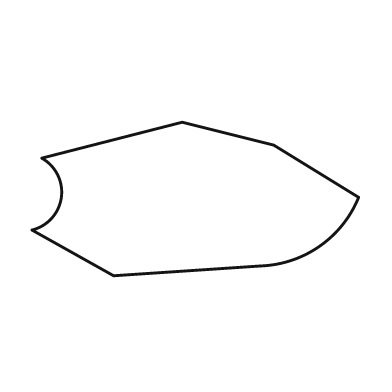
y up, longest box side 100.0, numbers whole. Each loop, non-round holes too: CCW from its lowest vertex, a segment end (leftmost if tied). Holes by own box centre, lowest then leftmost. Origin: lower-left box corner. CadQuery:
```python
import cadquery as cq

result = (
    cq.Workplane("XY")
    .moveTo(25.0, 0.0)
    .lineTo(70.0, 3.0)
    .threePointArc((88.0, 9.0), (100.0, 24.0))
    .lineTo(74.0, 40.0)
    .lineTo(46.0, 47.0)
    .lineTo(3.0, 36.0)
    .threePointArc((9.0, 24.0), (0.0, 14.0))
    .close()
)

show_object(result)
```